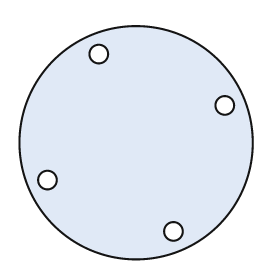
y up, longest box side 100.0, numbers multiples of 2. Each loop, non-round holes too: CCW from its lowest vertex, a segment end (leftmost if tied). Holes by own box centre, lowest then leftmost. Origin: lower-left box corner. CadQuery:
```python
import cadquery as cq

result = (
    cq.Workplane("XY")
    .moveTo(50.0, 50.0)
    .circle(50.0)
    .moveTo(66.0, 12.0)
    .circle(4.0)
    .moveTo(12.0, 34.0)
    .circle(4.0)
    .moveTo(88.0, 66.0)
    .circle(4.0)
    .moveTo(34.0, 88.0)
    .circle(4.0)
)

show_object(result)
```